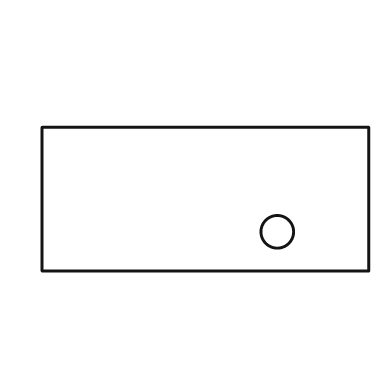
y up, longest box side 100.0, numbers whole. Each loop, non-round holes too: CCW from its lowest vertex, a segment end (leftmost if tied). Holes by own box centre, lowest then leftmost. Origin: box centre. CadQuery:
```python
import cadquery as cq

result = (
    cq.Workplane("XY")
    .moveTo(-50.0, -22.0)
    .lineTo(50.0, -22.0)
    .lineTo(50.0, 22.0)
    .lineTo(-50.0, 22.0)
    .close()
    .moveTo(22.0, -10.0)
    .circle(5.0)
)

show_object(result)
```